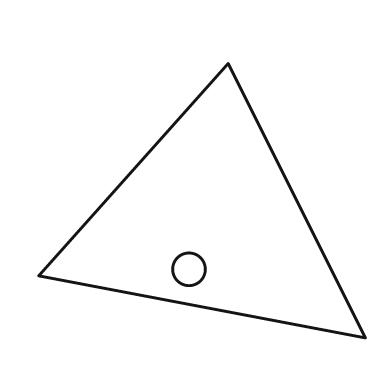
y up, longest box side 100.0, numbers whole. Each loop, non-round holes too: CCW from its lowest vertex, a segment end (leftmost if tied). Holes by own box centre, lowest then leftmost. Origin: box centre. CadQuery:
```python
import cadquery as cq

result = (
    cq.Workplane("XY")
    .moveTo(50.0, -42.0)
    .lineTo(8.0, 42.0)
    .lineTo(-50.0, -23.0)
    .close()
    .moveTo(-4.0, -21.0)
    .circle(5.0)
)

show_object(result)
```